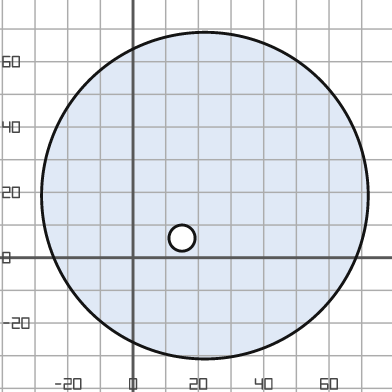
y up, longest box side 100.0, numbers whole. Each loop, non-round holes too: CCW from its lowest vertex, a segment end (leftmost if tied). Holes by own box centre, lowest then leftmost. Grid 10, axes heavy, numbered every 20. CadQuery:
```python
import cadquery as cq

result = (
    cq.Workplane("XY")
    .moveTo(22.0, 19.0)
    .circle(50.0)
    .moveTo(15.0, 6.0)
    .circle(4.0)
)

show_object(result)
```